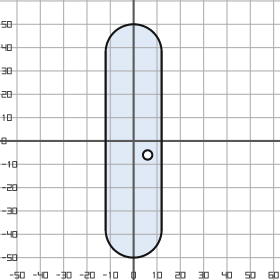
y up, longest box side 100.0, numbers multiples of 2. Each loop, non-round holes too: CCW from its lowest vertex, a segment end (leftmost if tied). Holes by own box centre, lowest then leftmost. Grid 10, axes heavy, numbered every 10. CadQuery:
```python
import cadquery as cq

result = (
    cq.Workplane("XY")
    .moveTo(-12.0, -38.0)
    .threePointArc((0.0, -50.0), (12.0, -38.0))
    .lineTo(12.0, 38.0)
    .threePointArc((0.0, 50.0), (-12.0, 38.0))
    .close()
    .moveTo(6.0, -6.0)
    .circle(2.0)
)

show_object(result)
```